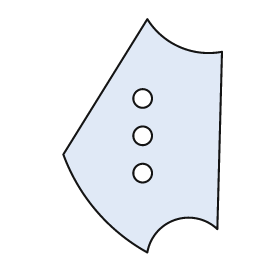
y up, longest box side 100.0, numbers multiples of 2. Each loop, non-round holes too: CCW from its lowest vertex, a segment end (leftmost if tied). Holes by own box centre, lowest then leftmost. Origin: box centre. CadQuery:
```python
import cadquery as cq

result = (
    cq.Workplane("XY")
    .moveTo(2.0, -50.0)
    .threePointArc((14.0, -36.0), (32.0, -40.0))
    .lineTo(34.0, 36.0)
    .threePointArc((16.0, 38.0), (2.0, 50.0))
    .lineTo(-34.0, -8.0)
    .threePointArc((-20.0, -32.0), (2.0, -50.0))
    .close()
    .moveTo(0.0, -16.0)
    .circle(4.0)
    .moveTo(0.0, 0.0)
    .circle(4.0)
    .moveTo(0.0, 16.0)
    .circle(4.0)
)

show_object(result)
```